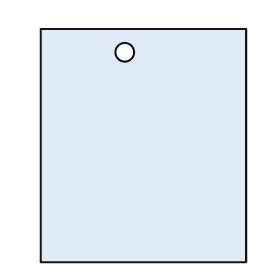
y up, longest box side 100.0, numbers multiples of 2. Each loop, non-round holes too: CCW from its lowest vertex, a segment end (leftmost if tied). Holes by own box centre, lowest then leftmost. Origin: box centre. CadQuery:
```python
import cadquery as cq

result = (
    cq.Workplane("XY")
    .moveTo(-44.0, -50.0)
    .lineTo(44.0, -50.0)
    .lineTo(44.0, 50.0)
    .lineTo(-44.0, 50.0)
    .close()
    .moveTo(-8.0, 40.0)
    .circle(4.0)
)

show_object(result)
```